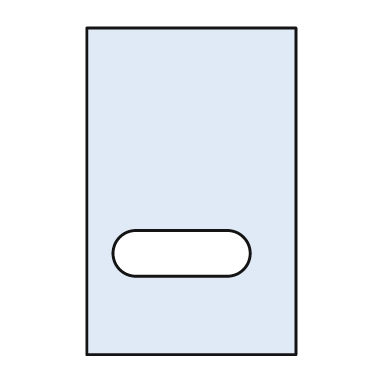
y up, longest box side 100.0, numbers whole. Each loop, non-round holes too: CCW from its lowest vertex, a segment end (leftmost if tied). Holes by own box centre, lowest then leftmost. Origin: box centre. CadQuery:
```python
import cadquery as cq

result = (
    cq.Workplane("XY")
    .moveTo(-32.0, -50.0)
    .lineTo(32.0, -50.0)
    .lineTo(32.0, 50.0)
    .lineTo(-32.0, 50.0)
    .close()
    .moveTo(-17.0, -26.0)
    .lineTo(11.0, -26.0)
    .threePointArc((18.0, -19.0), (11.0, -12.0))
    .lineTo(-17.0, -12.0)
    .threePointArc((-24.0, -19.0), (-17.0, -26.0))
    .close()
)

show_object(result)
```